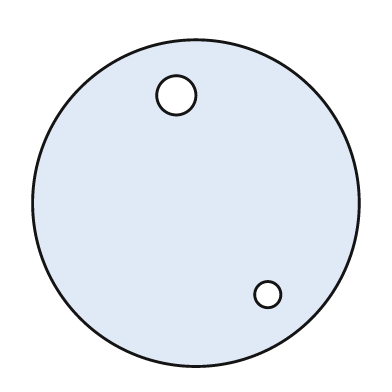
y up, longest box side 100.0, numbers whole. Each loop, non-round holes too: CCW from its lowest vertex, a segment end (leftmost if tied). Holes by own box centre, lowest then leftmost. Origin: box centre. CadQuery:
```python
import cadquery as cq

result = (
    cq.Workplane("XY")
    .moveTo(0.0, 0.0)
    .circle(50.0)
    .moveTo(22.0, -28.0)
    .circle(4.0)
    .moveTo(-6.0, 33.0)
    .circle(6.0)
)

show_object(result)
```